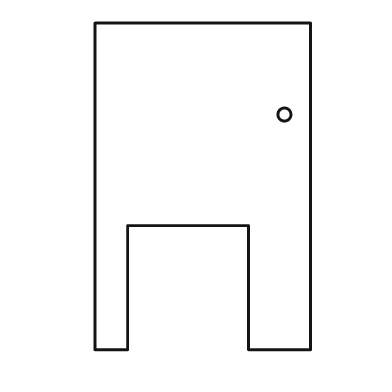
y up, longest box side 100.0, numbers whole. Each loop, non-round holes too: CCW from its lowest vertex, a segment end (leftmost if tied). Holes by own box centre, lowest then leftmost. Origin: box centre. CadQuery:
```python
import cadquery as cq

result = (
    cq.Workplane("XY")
    .moveTo(-33.0, -50.0)
    .lineTo(-23.0, -50.0)
    .lineTo(-23.0, -12.0)
    .lineTo(14.0, -12.0)
    .lineTo(14.0, -50.0)
    .lineTo(33.0, -50.0)
    .lineTo(33.0, 50.0)
    .lineTo(-33.0, 50.0)
    .close()
    .moveTo(25.0, 22.0)
    .circle(2.0)
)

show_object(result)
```